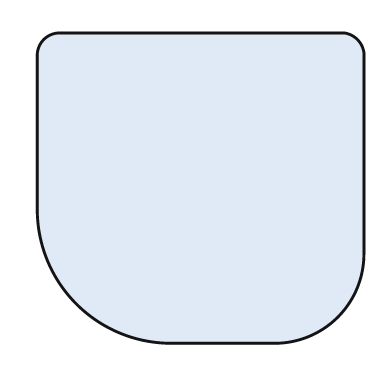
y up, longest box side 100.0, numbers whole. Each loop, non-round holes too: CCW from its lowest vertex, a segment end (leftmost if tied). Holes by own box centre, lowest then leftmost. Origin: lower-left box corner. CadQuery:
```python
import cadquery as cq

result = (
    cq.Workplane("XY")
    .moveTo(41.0, 0.0)
    .lineTo(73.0, 0.0)
    .threePointArc((92.0, 8.0), (100.0, 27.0))
    .lineTo(100.0, 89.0)
    .threePointArc((98.0, 93.0), (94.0, 95.0))
    .lineTo(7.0, 95.0)
    .threePointArc((2.0, 93.0), (0.0, 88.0))
    .lineTo(0.0, 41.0)
    .threePointArc((12.0, 12.0), (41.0, 0.0))
    .close()
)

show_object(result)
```